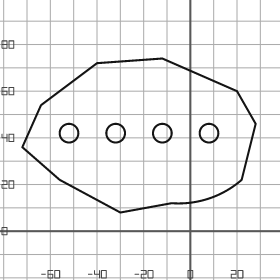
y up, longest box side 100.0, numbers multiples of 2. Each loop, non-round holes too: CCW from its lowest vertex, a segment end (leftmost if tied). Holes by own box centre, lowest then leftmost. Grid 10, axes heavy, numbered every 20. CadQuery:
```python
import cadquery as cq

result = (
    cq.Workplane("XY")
    .moveTo(-30.0, 8.0)
    .lineTo(-8.0, 12.0)
    .threePointArc((8.0, 14.0), (22.0, 22.0))
    .lineTo(28.0, 46.0)
    .lineTo(20.0, 60.0)
    .lineTo(-12.0, 74.0)
    .lineTo(-40.0, 72.0)
    .lineTo(-64.0, 54.0)
    .lineTo(-72.0, 36.0)
    .lineTo(-56.0, 22.0)
    .close()
    .moveTo(-52.0, 42.0)
    .circle(4.0)
    .moveTo(-32.0, 42.0)
    .circle(4.0)
    .moveTo(-12.0, 42.0)
    .circle(4.0)
    .moveTo(8.0, 42.0)
    .circle(4.0)
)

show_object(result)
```